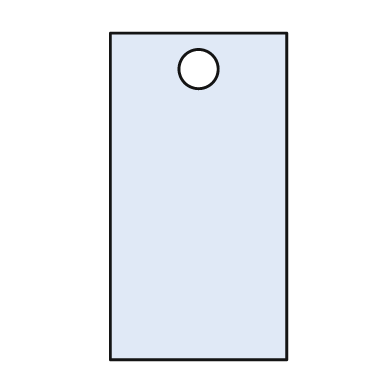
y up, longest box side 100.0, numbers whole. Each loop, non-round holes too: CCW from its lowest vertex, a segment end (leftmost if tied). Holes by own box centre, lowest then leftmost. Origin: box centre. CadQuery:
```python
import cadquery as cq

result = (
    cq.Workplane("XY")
    .moveTo(-27.0, -50.0)
    .lineTo(27.0, -50.0)
    .lineTo(27.0, 50.0)
    .lineTo(-27.0, 50.0)
    .close()
    .moveTo(0.0, 39.0)
    .circle(6.0)
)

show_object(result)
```